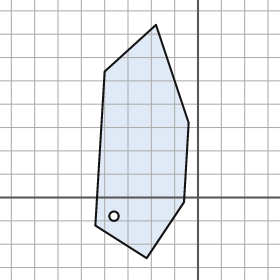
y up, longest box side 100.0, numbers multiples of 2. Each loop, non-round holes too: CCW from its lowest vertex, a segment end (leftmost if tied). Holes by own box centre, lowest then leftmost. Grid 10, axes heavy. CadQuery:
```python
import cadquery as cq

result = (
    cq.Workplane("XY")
    .moveTo(-22.0, -26.0)
    .lineTo(-6.0, -2.0)
    .lineTo(-4.0, 32.0)
    .lineTo(-18.0, 74.0)
    .lineTo(-40.0, 54.0)
    .lineTo(-44.0, -12.0)
    .close()
    .moveTo(-36.0, -8.0)
    .circle(2.0)
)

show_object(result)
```